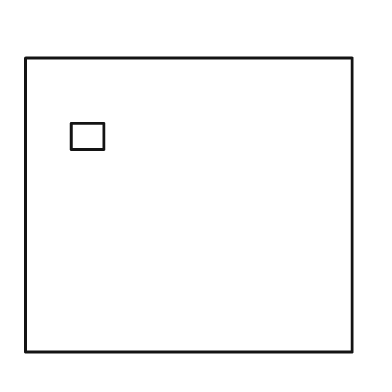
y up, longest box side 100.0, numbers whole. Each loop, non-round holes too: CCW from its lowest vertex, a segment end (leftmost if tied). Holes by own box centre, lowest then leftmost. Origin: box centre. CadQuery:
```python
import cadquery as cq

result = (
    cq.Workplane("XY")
    .moveTo(-50.0, -45.0)
    .lineTo(50.0, -45.0)
    .lineTo(50.0, 45.0)
    .lineTo(-50.0, 45.0)
    .close()
    .moveTo(-36.0, 17.0)
    .lineTo(-26.0, 17.0)
    .lineTo(-26.0, 25.0)
    .lineTo(-36.0, 25.0)
    .close()
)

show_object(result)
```